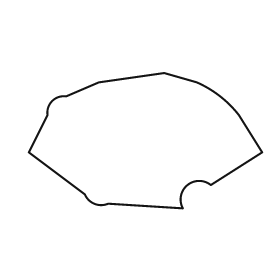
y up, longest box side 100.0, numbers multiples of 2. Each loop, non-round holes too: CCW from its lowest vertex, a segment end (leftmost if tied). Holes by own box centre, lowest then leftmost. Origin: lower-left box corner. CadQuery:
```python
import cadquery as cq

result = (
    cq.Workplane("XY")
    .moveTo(66.0, 0.0)
    .threePointArc((68.0, 10.0), (78.0, 10.0))
    .lineTo(100.0, 24.0)
    .lineTo(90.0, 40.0)
    .threePointArc((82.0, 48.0), (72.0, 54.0))
    .lineTo(58.0, 58.0)
    .lineTo(30.0, 54.0)
    .lineTo(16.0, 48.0)
    .threePointArc((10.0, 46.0), (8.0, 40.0))
    .lineTo(0.0, 24.0)
    .lineTo(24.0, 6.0)
    .threePointArc((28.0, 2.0), (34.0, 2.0))
    .close()
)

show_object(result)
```